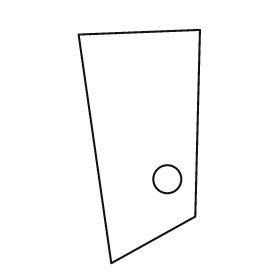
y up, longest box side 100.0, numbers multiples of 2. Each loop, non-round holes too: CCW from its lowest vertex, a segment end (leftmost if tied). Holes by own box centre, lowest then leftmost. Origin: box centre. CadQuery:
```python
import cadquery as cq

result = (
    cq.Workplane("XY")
    .moveTo(-12.0, -50.0)
    .lineTo(24.0, -30.0)
    .lineTo(26.0, 50.0)
    .lineTo(-26.0, 48.0)
    .close()
    .moveTo(12.0, -14.0)
    .circle(6.0)
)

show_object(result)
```